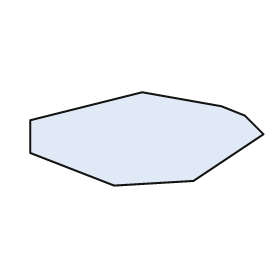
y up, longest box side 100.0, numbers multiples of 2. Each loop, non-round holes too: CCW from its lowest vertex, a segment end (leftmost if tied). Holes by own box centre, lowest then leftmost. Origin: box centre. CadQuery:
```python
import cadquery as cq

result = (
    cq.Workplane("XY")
    .moveTo(-14.0, -20.0)
    .lineTo(20.0, -18.0)
    .lineTo(50.0, 2.0)
    .lineTo(42.0, 10.0)
    .lineTo(32.0, 14.0)
    .lineTo(-2.0, 20.0)
    .lineTo(-50.0, 8.0)
    .lineTo(-50.0, -6.0)
    .close()
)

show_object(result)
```